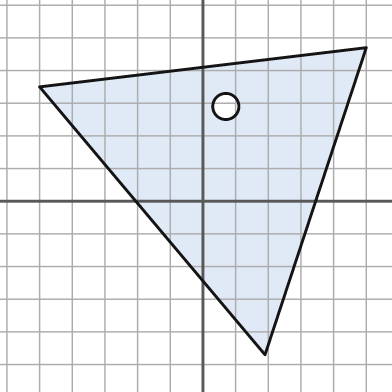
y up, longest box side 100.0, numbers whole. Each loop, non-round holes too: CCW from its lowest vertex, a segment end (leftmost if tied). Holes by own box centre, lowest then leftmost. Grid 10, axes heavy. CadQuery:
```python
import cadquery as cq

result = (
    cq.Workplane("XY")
    .moveTo(19.0, -47.0)
    .lineTo(50.0, 47.0)
    .lineTo(-50.0, 35.0)
    .close()
    .moveTo(7.0, 29.0)
    .circle(4.0)
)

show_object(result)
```